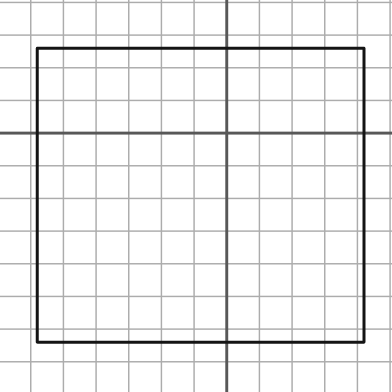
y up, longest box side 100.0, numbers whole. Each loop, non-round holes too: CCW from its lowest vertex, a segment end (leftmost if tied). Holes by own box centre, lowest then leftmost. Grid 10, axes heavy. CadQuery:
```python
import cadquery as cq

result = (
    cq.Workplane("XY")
    .moveTo(-58.0, -64.0)
    .lineTo(42.0, -64.0)
    .lineTo(42.0, 26.0)
    .lineTo(-58.0, 26.0)
    .close()
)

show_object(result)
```